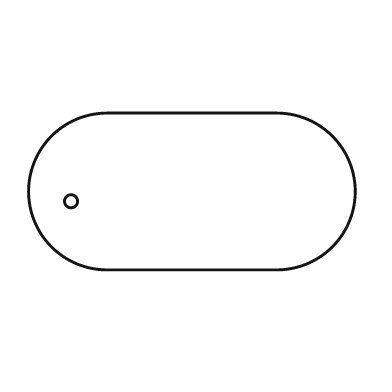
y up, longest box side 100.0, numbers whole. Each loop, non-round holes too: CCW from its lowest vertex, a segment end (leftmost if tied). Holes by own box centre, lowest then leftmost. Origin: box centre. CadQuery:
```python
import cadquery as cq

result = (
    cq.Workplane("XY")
    .moveTo(-26.0, -24.0)
    .lineTo(26.0, -24.0)
    .threePointArc((50.0, 0.0), (26.0, 24.0))
    .lineTo(-26.0, 24.0)
    .threePointArc((-50.0, 0.0), (-26.0, -24.0))
    .close()
    .moveTo(-37.0, -3.0)
    .circle(2.0)
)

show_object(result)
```